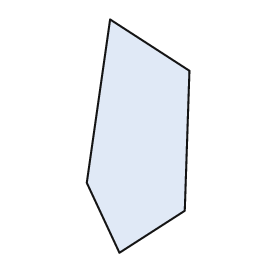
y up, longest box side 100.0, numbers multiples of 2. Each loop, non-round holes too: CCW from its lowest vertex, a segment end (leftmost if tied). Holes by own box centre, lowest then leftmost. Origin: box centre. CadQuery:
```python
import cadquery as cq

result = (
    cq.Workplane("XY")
    .moveTo(-8.0, -50.0)
    .lineTo(20.0, -32.0)
    .lineTo(22.0, 28.0)
    .lineTo(-12.0, 50.0)
    .lineTo(-22.0, -20.0)
    .close()
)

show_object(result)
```